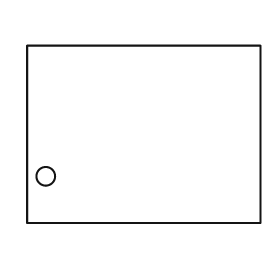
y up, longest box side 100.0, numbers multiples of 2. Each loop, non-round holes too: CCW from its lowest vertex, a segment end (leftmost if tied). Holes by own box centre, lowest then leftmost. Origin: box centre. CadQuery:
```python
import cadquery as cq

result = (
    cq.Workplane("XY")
    .moveTo(-50.0, -38.0)
    .lineTo(50.0, -38.0)
    .lineTo(50.0, 38.0)
    .lineTo(-50.0, 38.0)
    .close()
    .moveTo(-42.0, -18.0)
    .circle(4.0)
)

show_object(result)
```